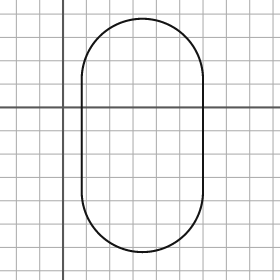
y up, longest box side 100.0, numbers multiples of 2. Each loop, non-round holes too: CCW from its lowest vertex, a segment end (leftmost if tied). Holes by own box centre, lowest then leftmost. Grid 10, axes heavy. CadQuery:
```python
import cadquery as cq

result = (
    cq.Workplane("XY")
    .moveTo(8.0, -36.0)
    .threePointArc((34.0, -62.0), (60.0, -36.0))
    .lineTo(60.0, 12.0)
    .threePointArc((34.0, 38.0), (8.0, 12.0))
    .close()
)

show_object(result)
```